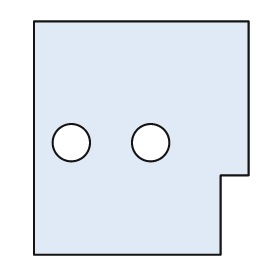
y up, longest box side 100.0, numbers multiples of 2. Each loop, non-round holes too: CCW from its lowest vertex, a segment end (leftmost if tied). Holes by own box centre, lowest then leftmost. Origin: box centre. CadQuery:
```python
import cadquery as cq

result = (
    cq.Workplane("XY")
    .moveTo(-46.0, -50.0)
    .lineTo(34.0, -50.0)
    .lineTo(34.0, -16.0)
    .lineTo(46.0, -16.0)
    .lineTo(46.0, 50.0)
    .lineTo(-46.0, 50.0)
    .close()
    .moveTo(-30.0, -2.0)
    .circle(8.0)
    .moveTo(4.0, -2.0)
    .circle(8.0)
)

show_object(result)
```